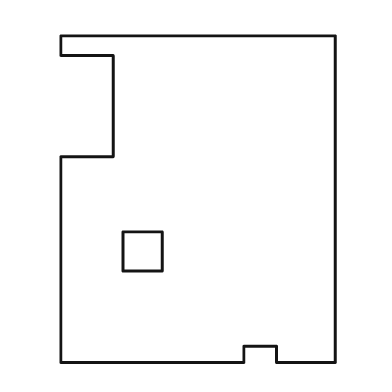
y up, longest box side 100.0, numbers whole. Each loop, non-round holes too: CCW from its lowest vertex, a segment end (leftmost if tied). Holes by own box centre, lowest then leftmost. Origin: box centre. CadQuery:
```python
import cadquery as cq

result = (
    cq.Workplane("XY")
    .moveTo(-42.0, -50.0)
    .lineTo(14.0, -50.0)
    .lineTo(14.0, -45.0)
    .lineTo(24.0, -45.0)
    .lineTo(24.0, -50.0)
    .lineTo(42.0, -50.0)
    .lineTo(42.0, 50.0)
    .lineTo(-42.0, 50.0)
    .lineTo(-42.0, 44.0)
    .lineTo(-26.0, 44.0)
    .lineTo(-26.0, 13.0)
    .lineTo(-42.0, 13.0)
    .close()
    .moveTo(-23.0, -22.0)
    .lineTo(-11.0, -22.0)
    .lineTo(-11.0, -10.0)
    .lineTo(-23.0, -10.0)
    .close()
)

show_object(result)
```